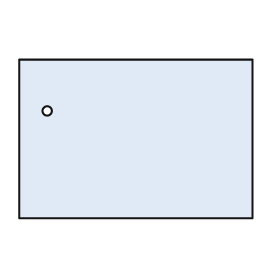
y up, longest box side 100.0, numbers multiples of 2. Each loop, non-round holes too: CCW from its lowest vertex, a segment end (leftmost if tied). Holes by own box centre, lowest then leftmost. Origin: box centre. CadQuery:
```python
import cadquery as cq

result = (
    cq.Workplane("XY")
    .moveTo(-50.0, -34.0)
    .lineTo(50.0, -34.0)
    .lineTo(50.0, 34.0)
    .lineTo(-50.0, 34.0)
    .close()
    .moveTo(-38.0, 12.0)
    .circle(2.0)
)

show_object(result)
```